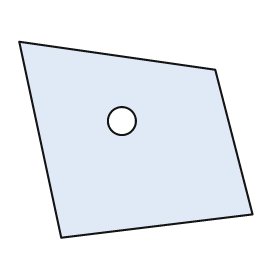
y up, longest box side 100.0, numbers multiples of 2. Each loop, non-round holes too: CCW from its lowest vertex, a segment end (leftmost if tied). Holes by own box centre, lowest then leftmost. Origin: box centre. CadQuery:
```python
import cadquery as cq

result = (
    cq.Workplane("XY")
    .moveTo(-32.0, -42.0)
    .lineTo(50.0, -32.0)
    .lineTo(34.0, 30.0)
    .lineTo(-50.0, 42.0)
    .close()
    .moveTo(-6.0, 8.0)
    .circle(6.0)
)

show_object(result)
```